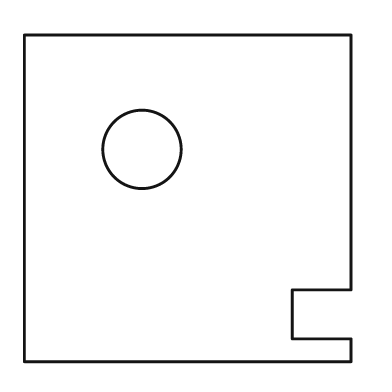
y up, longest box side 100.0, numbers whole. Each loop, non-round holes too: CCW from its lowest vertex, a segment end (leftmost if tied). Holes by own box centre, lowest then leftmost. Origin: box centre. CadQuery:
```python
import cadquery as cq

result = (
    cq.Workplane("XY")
    .moveTo(-50.0, -50.0)
    .lineTo(50.0, -50.0)
    .lineTo(50.0, -43.0)
    .lineTo(32.0, -43.0)
    .lineTo(32.0, -28.0)
    .lineTo(50.0, -28.0)
    .lineTo(50.0, 50.0)
    .lineTo(-50.0, 50.0)
    .close()
    .moveTo(-14.0, 15.0)
    .circle(12.0)
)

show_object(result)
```